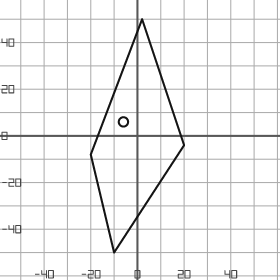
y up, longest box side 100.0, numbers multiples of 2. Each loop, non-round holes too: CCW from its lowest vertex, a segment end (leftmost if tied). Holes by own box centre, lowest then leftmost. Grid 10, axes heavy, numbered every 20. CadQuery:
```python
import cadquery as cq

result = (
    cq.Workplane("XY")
    .moveTo(-10.0, -50.0)
    .lineTo(20.0, -4.0)
    .lineTo(2.0, 50.0)
    .lineTo(-20.0, -8.0)
    .close()
    .moveTo(-6.0, 6.0)
    .circle(2.0)
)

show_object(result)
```